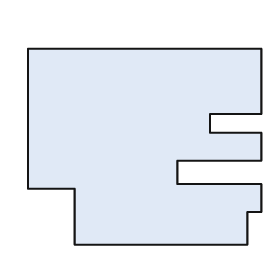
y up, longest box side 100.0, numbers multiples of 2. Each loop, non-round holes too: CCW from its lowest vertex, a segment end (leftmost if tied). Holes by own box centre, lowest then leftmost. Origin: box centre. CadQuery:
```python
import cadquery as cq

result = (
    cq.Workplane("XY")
    .moveTo(-30.0, -42.0)
    .lineTo(44.0, -42.0)
    .lineTo(44.0, -28.0)
    .lineTo(50.0, -28.0)
    .lineTo(50.0, -16.0)
    .lineTo(14.0, -16.0)
    .lineTo(14.0, -6.0)
    .lineTo(50.0, -6.0)
    .lineTo(50.0, 6.0)
    .lineTo(28.0, 6.0)
    .lineTo(28.0, 14.0)
    .lineTo(50.0, 14.0)
    .lineTo(50.0, 42.0)
    .lineTo(-50.0, 42.0)
    .lineTo(-50.0, -18.0)
    .lineTo(-30.0, -18.0)
    .close()
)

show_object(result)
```